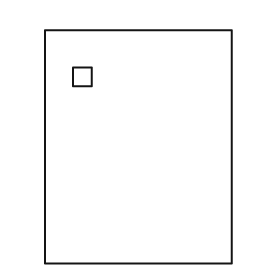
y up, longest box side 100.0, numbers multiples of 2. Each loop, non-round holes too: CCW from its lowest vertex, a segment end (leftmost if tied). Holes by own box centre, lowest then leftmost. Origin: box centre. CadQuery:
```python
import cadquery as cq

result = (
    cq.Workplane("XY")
    .moveTo(-40.0, -50.0)
    .lineTo(40.0, -50.0)
    .lineTo(40.0, 50.0)
    .lineTo(-40.0, 50.0)
    .close()
    .moveTo(-28.0, 26.0)
    .lineTo(-20.0, 26.0)
    .lineTo(-20.0, 34.0)
    .lineTo(-28.0, 34.0)
    .close()
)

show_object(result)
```